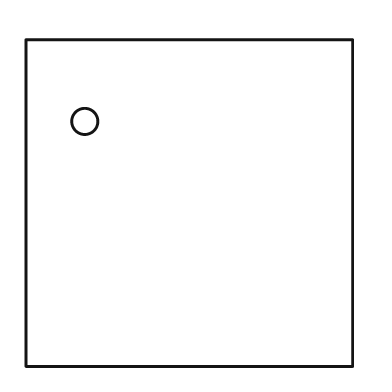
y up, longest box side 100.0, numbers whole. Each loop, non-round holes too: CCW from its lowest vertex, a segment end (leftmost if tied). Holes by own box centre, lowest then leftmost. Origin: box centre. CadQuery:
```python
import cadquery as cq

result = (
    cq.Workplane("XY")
    .moveTo(-50.0, -50.0)
    .lineTo(50.0, -50.0)
    .lineTo(50.0, 50.0)
    .lineTo(-50.0, 50.0)
    .close()
    .moveTo(-32.0, 25.0)
    .circle(4.0)
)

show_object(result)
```